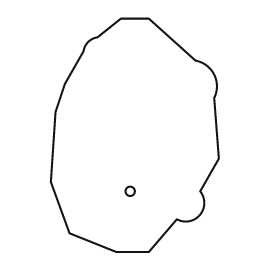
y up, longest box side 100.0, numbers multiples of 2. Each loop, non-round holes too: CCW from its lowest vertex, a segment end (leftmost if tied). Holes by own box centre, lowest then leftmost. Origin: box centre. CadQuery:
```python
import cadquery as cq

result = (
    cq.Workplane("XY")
    .moveTo(-8.0, -50.0)
    .lineTo(6.0, -50.0)
    .lineTo(18.0, -36.0)
    .threePointArc((28.0, -34.0), (28.0, -24.0))
    .lineTo(36.0, -10.0)
    .lineTo(34.0, 16.0)
    .threePointArc((34.0, 26.0), (26.0, 32.0))
    .lineTo(6.0, 50.0)
    .lineTo(-6.0, 50.0)
    .lineTo(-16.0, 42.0)
    .threePointArc((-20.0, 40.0), (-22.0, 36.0))
    .lineTo(-30.0, 22.0)
    .lineTo(-34.0, 10.0)
    .lineTo(-36.0, -20.0)
    .lineTo(-28.0, -42.0)
    .close()
    .moveTo(-2.0, -24.0)
    .circle(2.0)
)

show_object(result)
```